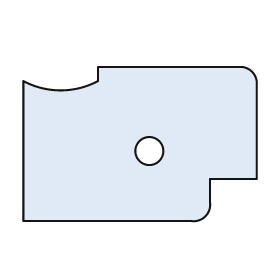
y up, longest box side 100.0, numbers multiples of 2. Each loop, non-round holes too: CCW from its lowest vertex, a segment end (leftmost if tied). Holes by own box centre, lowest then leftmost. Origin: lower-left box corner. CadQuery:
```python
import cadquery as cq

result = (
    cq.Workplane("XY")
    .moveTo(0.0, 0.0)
    .lineTo(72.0, 0.0)
    .threePointArc((78.0, 2.0), (80.0, 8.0))
    .lineTo(80.0, 18.0)
    .lineTo(100.0, 18.0)
    .lineTo(100.0, 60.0)
    .threePointArc((98.0, 64.0), (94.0, 66.0))
    .lineTo(32.0, 66.0)
    .lineTo(32.0, 60.0)
    .threePointArc((16.0, 56.0), (0.0, 60.0))
    .close()
    .moveTo(54.0, 30.0)
    .circle(6.0)
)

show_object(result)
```